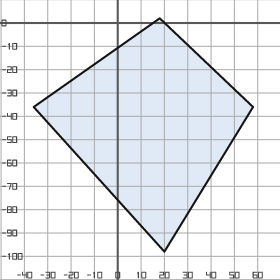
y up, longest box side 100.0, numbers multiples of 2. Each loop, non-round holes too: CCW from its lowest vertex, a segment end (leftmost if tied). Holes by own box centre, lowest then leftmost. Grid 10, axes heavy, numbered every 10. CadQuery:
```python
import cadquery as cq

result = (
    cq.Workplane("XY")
    .moveTo(20.0, -98.0)
    .lineTo(58.0, -36.0)
    .lineTo(18.0, 2.0)
    .lineTo(-36.0, -36.0)
    .close()
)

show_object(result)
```